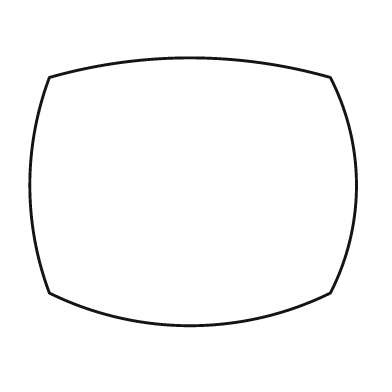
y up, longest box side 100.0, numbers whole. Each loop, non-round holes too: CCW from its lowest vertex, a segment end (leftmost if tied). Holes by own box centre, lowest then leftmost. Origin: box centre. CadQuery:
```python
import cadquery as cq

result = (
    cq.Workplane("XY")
    .moveTo(-44.0, -31.0)
    .threePointArc((-1.0, -41.0), (42.0, -31.0))
    .threePointArc((50.0, 2.0), (42.0, 35.0))
    .threePointArc((-1.0, 41.0), (-44.0, 35.0))
    .threePointArc((-50.0, 2.0), (-44.0, -31.0))
    .close()
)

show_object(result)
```